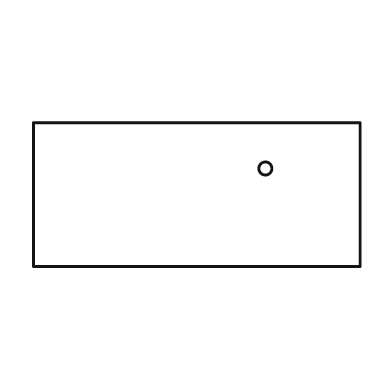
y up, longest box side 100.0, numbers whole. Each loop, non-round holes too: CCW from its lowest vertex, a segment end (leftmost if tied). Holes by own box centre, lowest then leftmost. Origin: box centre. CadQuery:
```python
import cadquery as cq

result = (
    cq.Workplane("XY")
    .moveTo(-50.0, -22.0)
    .lineTo(50.0, -22.0)
    .lineTo(50.0, 22.0)
    .lineTo(-50.0, 22.0)
    .close()
    .moveTo(21.0, 8.0)
    .circle(2.0)
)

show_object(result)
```